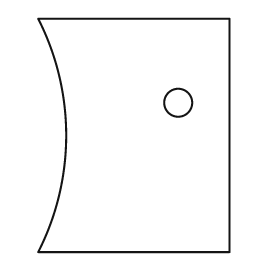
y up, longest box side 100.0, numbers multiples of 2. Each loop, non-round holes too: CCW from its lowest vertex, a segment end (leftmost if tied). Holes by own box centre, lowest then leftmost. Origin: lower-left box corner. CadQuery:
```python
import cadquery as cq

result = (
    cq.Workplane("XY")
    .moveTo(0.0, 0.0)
    .lineTo(82.0, 0.0)
    .lineTo(82.0, 100.0)
    .lineTo(0.0, 100.0)
    .threePointArc((12.0, 50.0), (0.0, 0.0))
    .close()
    .moveTo(60.0, 64.0)
    .circle(6.0)
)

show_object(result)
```